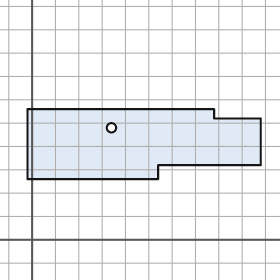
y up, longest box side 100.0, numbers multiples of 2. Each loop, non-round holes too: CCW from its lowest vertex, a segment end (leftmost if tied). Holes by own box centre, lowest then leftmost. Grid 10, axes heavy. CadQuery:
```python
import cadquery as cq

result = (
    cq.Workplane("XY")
    .moveTo(-2.0, 26.0)
    .lineTo(54.0, 26.0)
    .lineTo(54.0, 32.0)
    .lineTo(98.0, 32.0)
    .lineTo(98.0, 52.0)
    .lineTo(78.0, 52.0)
    .lineTo(78.0, 56.0)
    .lineTo(-2.0, 56.0)
    .close()
    .moveTo(34.0, 48.0)
    .circle(2.0)
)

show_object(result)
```